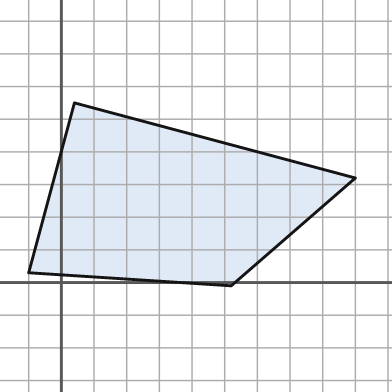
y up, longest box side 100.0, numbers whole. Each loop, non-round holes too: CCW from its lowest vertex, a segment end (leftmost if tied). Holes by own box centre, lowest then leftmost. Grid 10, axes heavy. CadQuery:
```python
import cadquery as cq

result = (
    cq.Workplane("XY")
    .moveTo(52.0, -1.0)
    .lineTo(90.0, 32.0)
    .lineTo(4.0, 55.0)
    .lineTo(-10.0, 3.0)
    .close()
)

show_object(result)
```